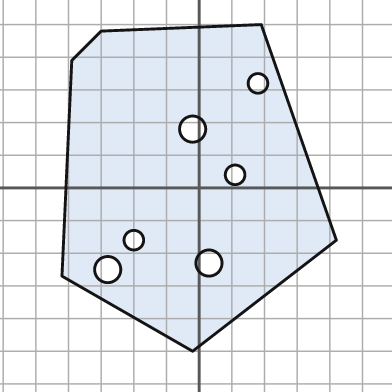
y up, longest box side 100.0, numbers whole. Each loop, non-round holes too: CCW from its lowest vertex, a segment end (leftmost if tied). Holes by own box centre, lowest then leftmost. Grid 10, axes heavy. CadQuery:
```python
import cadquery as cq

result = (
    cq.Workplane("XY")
    .moveTo(-2.0, -50.0)
    .lineTo(42.0, -16.0)
    .lineTo(19.0, 50.0)
    .lineTo(-30.0, 48.0)
    .lineTo(-39.0, 39.0)
    .lineTo(-42.0, -27.0)
    .close()
    .moveTo(-28.0, -25.0)
    .circle(4.0)
    .moveTo(3.0, -23.0)
    .circle(4.0)
    .moveTo(-20.0, -16.0)
    .circle(3.0)
    .moveTo(11.0, 4.0)
    .circle(3.0)
    .moveTo(-2.0, 18.0)
    .circle(4.0)
    .moveTo(18.0, 32.0)
    .circle(3.0)
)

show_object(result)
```